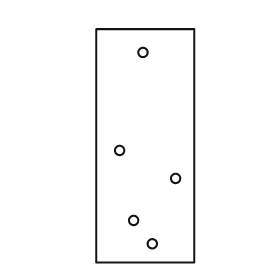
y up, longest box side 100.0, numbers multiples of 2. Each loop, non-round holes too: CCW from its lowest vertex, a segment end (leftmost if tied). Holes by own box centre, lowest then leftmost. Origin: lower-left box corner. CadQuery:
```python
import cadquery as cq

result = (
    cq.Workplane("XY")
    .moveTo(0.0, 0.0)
    .lineTo(42.0, 0.0)
    .lineTo(42.0, 100.0)
    .lineTo(0.0, 100.0)
    .close()
    .moveTo(24.0, 8.0)
    .circle(2.0)
    .moveTo(16.0, 18.0)
    .circle(2.0)
    .moveTo(34.0, 36.0)
    .circle(2.0)
    .moveTo(10.0, 48.0)
    .circle(2.0)
    .moveTo(20.0, 90.0)
    .circle(2.0)
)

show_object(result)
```